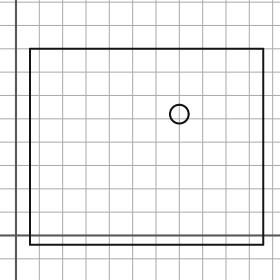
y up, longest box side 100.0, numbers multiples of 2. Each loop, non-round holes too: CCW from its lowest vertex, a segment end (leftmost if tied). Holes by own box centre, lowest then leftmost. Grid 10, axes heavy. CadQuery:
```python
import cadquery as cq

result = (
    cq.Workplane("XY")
    .moveTo(6.0, -4.0)
    .lineTo(106.0, -4.0)
    .lineTo(106.0, 80.0)
    .lineTo(6.0, 80.0)
    .close()
    .moveTo(70.0, 52.0)
    .circle(4.0)
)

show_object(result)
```